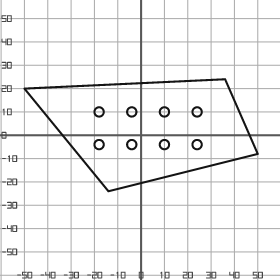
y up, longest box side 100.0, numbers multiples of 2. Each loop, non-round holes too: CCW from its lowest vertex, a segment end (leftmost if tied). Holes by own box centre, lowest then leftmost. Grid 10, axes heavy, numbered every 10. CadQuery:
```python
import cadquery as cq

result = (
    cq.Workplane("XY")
    .moveTo(-14.0, -24.0)
    .lineTo(50.0, -8.0)
    .lineTo(36.0, 24.0)
    .lineTo(-50.0, 20.0)
    .close()
    .moveTo(-18.0, -4.0)
    .circle(2.0)
    .moveTo(-4.0, -4.0)
    .circle(2.0)
    .moveTo(10.0, -4.0)
    .circle(2.0)
    .moveTo(24.0, -4.0)
    .circle(2.0)
    .moveTo(-18.0, 10.0)
    .circle(2.0)
    .moveTo(-4.0, 10.0)
    .circle(2.0)
    .moveTo(10.0, 10.0)
    .circle(2.0)
    .moveTo(24.0, 10.0)
    .circle(2.0)
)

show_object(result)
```